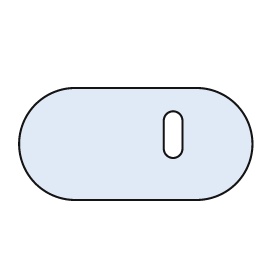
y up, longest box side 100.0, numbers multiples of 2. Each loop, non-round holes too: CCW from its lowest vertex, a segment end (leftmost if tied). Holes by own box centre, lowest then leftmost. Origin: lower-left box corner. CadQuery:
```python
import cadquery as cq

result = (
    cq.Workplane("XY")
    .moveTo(24.0, 0.0)
    .lineTo(76.0, 0.0)
    .threePointArc((100.0, 24.0), (76.0, 48.0))
    .lineTo(24.0, 48.0)
    .threePointArc((0.0, 24.0), (24.0, 0.0))
    .close()
    .moveTo(62.0, 22.0)
    .threePointArc((66.0, 18.0), (70.0, 22.0))
    .lineTo(70.0, 34.0)
    .threePointArc((66.0, 38.0), (62.0, 34.0))
    .close()
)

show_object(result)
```